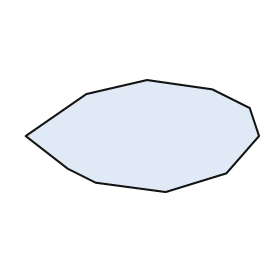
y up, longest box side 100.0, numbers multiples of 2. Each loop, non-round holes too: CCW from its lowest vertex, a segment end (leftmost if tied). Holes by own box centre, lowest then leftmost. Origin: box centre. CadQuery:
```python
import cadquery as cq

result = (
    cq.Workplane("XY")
    .moveTo(10.0, -24.0)
    .lineTo(36.0, -16.0)
    .lineTo(50.0, 0.0)
    .lineTo(46.0, 12.0)
    .lineTo(30.0, 20.0)
    .lineTo(2.0, 24.0)
    .lineTo(-24.0, 18.0)
    .lineTo(-50.0, 0.0)
    .lineTo(-32.0, -14.0)
    .lineTo(-20.0, -20.0)
    .close()
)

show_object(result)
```